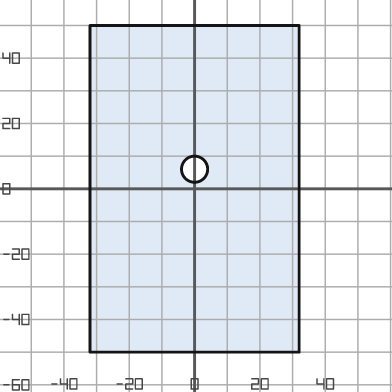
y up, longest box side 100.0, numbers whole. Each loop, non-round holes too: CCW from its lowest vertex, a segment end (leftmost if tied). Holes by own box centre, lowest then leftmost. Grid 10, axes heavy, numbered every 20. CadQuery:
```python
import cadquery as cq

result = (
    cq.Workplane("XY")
    .moveTo(-32.0, -50.0)
    .lineTo(32.0, -50.0)
    .lineTo(32.0, 50.0)
    .lineTo(-32.0, 50.0)
    .close()
    .moveTo(0.0, 6.0)
    .circle(4.0)
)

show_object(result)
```